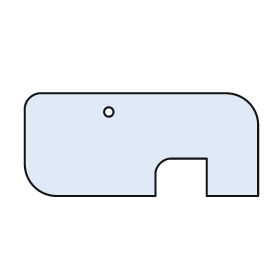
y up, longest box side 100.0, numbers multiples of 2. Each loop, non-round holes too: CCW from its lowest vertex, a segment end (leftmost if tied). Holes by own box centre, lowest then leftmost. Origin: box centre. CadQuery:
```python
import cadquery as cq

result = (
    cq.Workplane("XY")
    .moveTo(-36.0, -22.0)
    .lineTo(6.0, -22.0)
    .lineTo(6.0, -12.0)
    .threePointArc((8.0, -8.0), (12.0, -6.0))
    .lineTo(28.0, -6.0)
    .lineTo(28.0, -22.0)
    .lineTo(50.0, -22.0)
    .lineTo(50.0, 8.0)
    .threePointArc((46.0, 18.0), (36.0, 22.0))
    .lineTo(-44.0, 22.0)
    .threePointArc((-48.0, 20.0), (-50.0, 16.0))
    .lineTo(-50.0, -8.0)
    .threePointArc((-46.0, -18.0), (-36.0, -22.0))
    .close()
    .moveTo(-14.0, 14.0)
    .circle(2.0)
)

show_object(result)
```